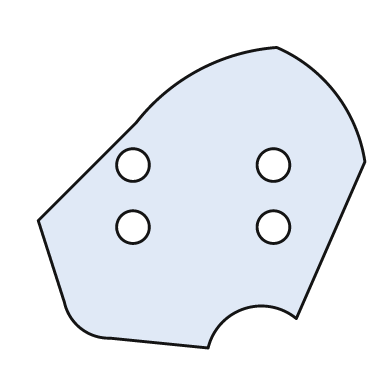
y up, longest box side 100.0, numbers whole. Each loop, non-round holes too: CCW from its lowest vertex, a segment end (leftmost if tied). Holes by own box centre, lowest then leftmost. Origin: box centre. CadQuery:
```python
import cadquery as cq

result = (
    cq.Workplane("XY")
    .moveTo(2.0, -46.0)
    .threePointArc((13.0, -34.0), (29.0, -37.0))
    .lineTo(50.0, 11.0)
    .threePointArc((41.0, 32.0), (23.0, 46.0))
    .threePointArc((-1.0, 39.0), (-20.0, 23.0))
    .lineTo(-50.0, -7.0)
    .lineTo(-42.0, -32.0)
    .threePointArc((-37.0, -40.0), (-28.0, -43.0))
    .close()
    .moveTo(-21.0, -9.0)
    .circle(5.0)
    .moveTo(22.0, -9.0)
    .circle(5.0)
    .moveTo(-21.0, 10.0)
    .circle(5.0)
    .moveTo(22.0, 10.0)
    .circle(5.0)
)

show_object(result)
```